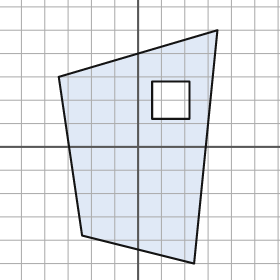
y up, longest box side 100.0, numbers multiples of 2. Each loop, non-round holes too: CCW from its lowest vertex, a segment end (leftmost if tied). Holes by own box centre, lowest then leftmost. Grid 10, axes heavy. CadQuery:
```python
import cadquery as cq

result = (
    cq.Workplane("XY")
    .moveTo(24.0, -50.0)
    .lineTo(34.0, 50.0)
    .lineTo(-34.0, 30.0)
    .lineTo(-24.0, -38.0)
    .close()
    .moveTo(6.0, 12.0)
    .lineTo(22.0, 12.0)
    .lineTo(22.0, 28.0)
    .lineTo(6.0, 28.0)
    .close()
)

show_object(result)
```